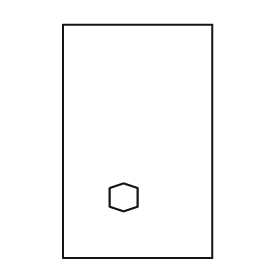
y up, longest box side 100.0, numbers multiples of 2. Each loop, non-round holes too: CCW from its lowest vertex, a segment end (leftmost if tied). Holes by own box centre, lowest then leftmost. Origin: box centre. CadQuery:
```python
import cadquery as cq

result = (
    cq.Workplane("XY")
    .moveTo(-32.0, -50.0)
    .lineTo(32.0, -50.0)
    .lineTo(32.0, 50.0)
    .lineTo(-32.0, 50.0)
    .close()
    .moveTo(-6.0, -30.0)
    .lineTo(0.0, -28.0)
    .lineTo(0.0, -20.0)
    .lineTo(-6.0, -18.0)
    .lineTo(-12.0, -20.0)
    .lineTo(-12.0, -28.0)
    .close()
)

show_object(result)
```